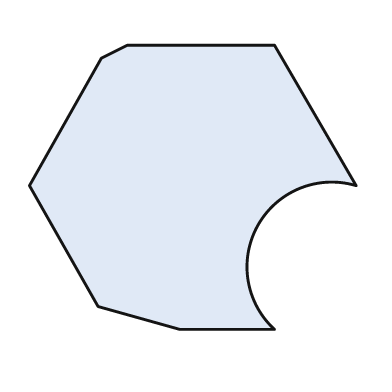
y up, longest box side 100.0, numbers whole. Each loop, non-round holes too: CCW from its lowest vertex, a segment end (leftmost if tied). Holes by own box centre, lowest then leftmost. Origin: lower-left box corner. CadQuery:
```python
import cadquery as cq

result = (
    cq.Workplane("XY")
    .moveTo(46.0, 0.0)
    .lineTo(75.0, 0.0)
    .threePointArc((70.0, 32.0), (100.0, 44.0))
    .lineTo(75.0, 87.0)
    .lineTo(30.0, 87.0)
    .lineTo(22.0, 83.0)
    .lineTo(0.0, 44.0)
    .lineTo(21.0, 7.0)
    .close()
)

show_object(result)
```